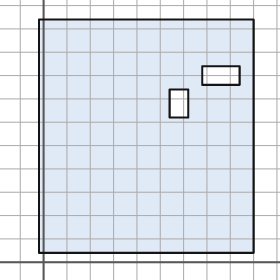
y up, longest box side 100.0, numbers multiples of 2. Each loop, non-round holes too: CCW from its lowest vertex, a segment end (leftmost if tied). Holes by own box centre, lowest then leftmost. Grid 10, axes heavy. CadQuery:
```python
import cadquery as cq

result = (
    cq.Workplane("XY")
    .moveTo(-2.0, 4.0)
    .lineTo(90.0, 4.0)
    .lineTo(90.0, 104.0)
    .lineTo(-2.0, 104.0)
    .close()
    .moveTo(54.0, 62.0)
    .lineTo(62.0, 62.0)
    .lineTo(62.0, 74.0)
    .lineTo(54.0, 74.0)
    .close()
    .moveTo(68.0, 76.0)
    .lineTo(84.0, 76.0)
    .lineTo(84.0, 84.0)
    .lineTo(68.0, 84.0)
    .close()
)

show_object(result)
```